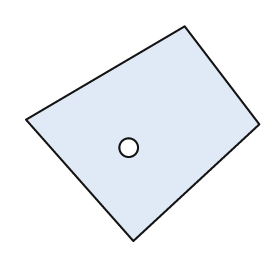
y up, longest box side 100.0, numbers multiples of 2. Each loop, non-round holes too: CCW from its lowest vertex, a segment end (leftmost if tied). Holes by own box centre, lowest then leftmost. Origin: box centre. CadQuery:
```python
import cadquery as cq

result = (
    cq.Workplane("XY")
    .moveTo(-4.0, -46.0)
    .lineTo(50.0, 4.0)
    .lineTo(18.0, 46.0)
    .lineTo(-50.0, 6.0)
    .close()
    .moveTo(-6.0, -6.0)
    .circle(4.0)
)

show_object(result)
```